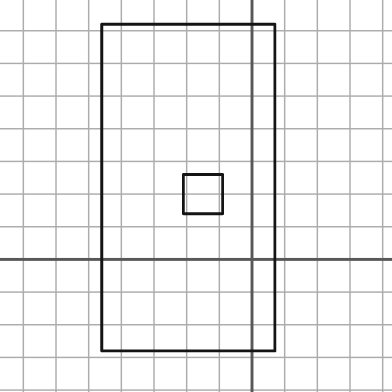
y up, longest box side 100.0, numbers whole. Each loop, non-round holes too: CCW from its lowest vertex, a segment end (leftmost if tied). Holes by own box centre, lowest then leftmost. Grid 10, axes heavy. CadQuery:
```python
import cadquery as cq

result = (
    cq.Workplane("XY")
    .moveTo(-46.0, -28.0)
    .lineTo(7.0, -28.0)
    .lineTo(7.0, 72.0)
    .lineTo(-46.0, 72.0)
    .close()
    .moveTo(-21.0, 14.0)
    .lineTo(-9.0, 14.0)
    .lineTo(-9.0, 26.0)
    .lineTo(-21.0, 26.0)
    .close()
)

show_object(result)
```